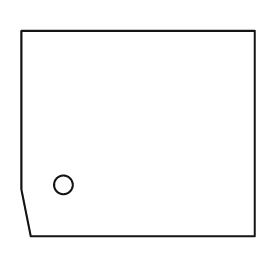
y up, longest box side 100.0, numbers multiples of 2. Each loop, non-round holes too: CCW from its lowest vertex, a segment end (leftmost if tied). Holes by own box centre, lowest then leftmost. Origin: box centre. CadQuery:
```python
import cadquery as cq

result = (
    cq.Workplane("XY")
    .moveTo(-46.0, -44.0)
    .lineTo(50.0, -44.0)
    .lineTo(50.0, 44.0)
    .lineTo(-50.0, 44.0)
    .lineTo(-50.0, -24.0)
    .close()
    .moveTo(-32.0, -22.0)
    .circle(4.0)
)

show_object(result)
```